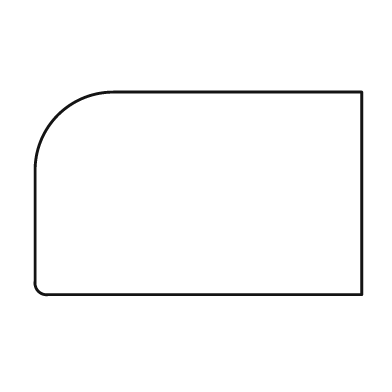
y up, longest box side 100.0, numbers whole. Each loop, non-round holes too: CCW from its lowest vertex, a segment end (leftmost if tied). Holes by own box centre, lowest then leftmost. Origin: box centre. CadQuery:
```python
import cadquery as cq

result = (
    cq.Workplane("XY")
    .moveTo(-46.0, -31.0)
    .lineTo(50.0, -31.0)
    .lineTo(50.0, 31.0)
    .lineTo(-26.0, 31.0)
    .threePointArc((-43.0, 24.0), (-50.0, 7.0))
    .lineTo(-50.0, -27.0)
    .threePointArc((-49.0, -30.0), (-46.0, -31.0))
    .close()
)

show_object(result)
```